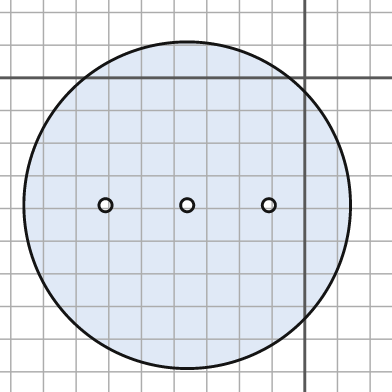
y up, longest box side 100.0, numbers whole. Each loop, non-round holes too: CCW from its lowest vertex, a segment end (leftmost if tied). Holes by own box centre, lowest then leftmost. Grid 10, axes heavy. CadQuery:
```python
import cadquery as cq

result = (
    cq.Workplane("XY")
    .moveTo(-36.0, -39.0)
    .circle(50.0)
    .moveTo(-61.0, -39.0)
    .circle(2.0)
    .moveTo(-36.0, -39.0)
    .circle(2.0)
    .moveTo(-11.0, -39.0)
    .circle(2.0)
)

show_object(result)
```